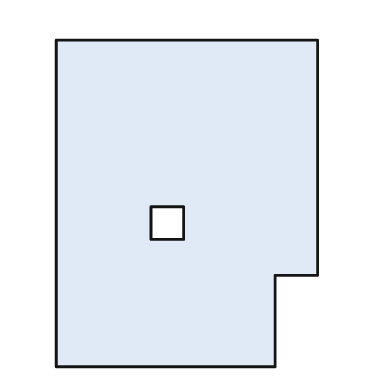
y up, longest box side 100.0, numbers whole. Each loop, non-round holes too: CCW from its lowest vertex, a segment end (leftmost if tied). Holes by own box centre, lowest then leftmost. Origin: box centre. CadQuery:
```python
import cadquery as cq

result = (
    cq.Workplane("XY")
    .moveTo(-40.0, -50.0)
    .lineTo(27.0, -50.0)
    .lineTo(27.0, -22.0)
    .lineTo(40.0, -22.0)
    .lineTo(40.0, 50.0)
    .lineTo(-40.0, 50.0)
    .close()
    .moveTo(-11.0, -11.0)
    .lineTo(-1.0, -11.0)
    .lineTo(-1.0, -1.0)
    .lineTo(-11.0, -1.0)
    .close()
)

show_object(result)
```